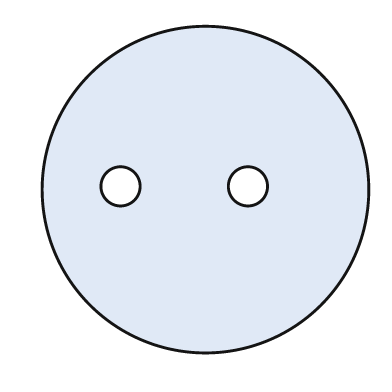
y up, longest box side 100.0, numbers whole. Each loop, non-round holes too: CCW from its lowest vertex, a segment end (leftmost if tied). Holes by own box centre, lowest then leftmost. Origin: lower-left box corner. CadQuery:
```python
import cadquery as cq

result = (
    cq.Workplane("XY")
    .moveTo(50.0, 50.0)
    .circle(50.0)
    .moveTo(24.0, 51.0)
    .circle(6.0)
    .moveTo(63.0, 51.0)
    .circle(6.0)
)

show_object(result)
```